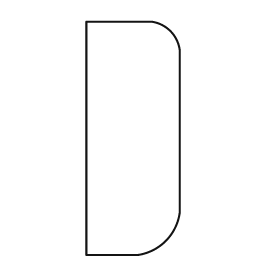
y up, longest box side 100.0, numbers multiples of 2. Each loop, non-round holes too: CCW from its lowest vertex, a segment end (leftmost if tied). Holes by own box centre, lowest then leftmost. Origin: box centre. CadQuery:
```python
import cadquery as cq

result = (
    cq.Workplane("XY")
    .moveTo(-20.0, -50.0)
    .lineTo(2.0, -50.0)
    .threePointArc((14.0, -44.0), (20.0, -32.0))
    .lineTo(20.0, 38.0)
    .threePointArc((16.0, 46.0), (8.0, 50.0))
    .lineTo(-20.0, 50.0)
    .close()
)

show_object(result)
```